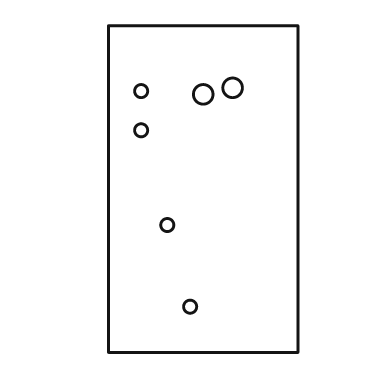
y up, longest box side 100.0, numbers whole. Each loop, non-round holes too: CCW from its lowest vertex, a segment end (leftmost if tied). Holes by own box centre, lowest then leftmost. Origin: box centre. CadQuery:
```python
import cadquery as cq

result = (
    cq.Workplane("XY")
    .moveTo(-29.0, -50.0)
    .lineTo(29.0, -50.0)
    .lineTo(29.0, 50.0)
    .lineTo(-29.0, 50.0)
    .close()
    .moveTo(-4.0, -36.0)
    .circle(2.0)
    .moveTo(-11.0, -11.0)
    .circle(2.0)
    .moveTo(-19.0, 18.0)
    .circle(2.0)
    .moveTo(0.0, 29.0)
    .circle(3.0)
    .moveTo(-19.0, 30.0)
    .circle(2.0)
    .moveTo(9.0, 31.0)
    .circle(3.0)
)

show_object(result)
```